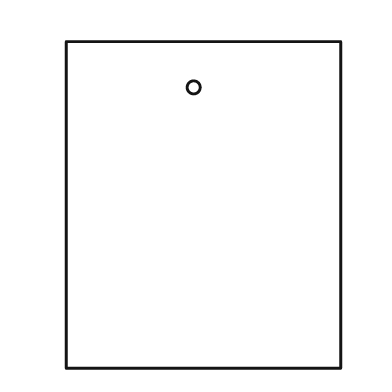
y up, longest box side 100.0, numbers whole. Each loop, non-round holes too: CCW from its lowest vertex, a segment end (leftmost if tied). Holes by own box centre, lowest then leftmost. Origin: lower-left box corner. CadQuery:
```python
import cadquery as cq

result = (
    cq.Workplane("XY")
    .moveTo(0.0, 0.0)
    .lineTo(84.0, 0.0)
    .lineTo(84.0, 100.0)
    .lineTo(0.0, 100.0)
    .close()
    .moveTo(39.0, 86.0)
    .circle(2.0)
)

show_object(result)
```